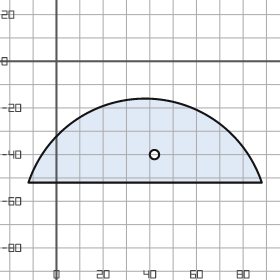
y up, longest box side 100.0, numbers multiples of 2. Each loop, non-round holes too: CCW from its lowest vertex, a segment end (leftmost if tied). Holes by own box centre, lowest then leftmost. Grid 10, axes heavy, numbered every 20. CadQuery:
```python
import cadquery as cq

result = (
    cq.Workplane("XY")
    .moveTo(-12.0, -52.0)
    .lineTo(88.0, -52.0)
    .threePointArc((38.0, -16.0), (-12.0, -52.0))
    .close()
    .moveTo(42.0, -40.0)
    .circle(2.0)
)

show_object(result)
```